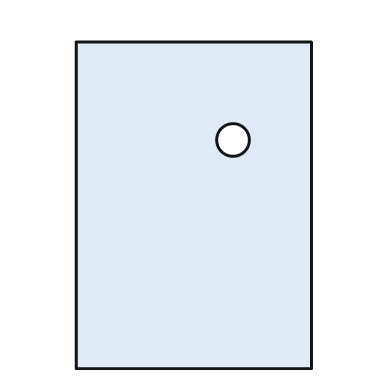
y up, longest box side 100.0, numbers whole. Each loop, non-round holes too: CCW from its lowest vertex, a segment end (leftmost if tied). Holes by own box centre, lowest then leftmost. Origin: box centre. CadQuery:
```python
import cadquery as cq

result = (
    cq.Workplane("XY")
    .moveTo(-36.0, -50.0)
    .lineTo(36.0, -50.0)
    .lineTo(36.0, 50.0)
    .lineTo(-36.0, 50.0)
    .close()
    .moveTo(12.0, 20.0)
    .circle(5.0)
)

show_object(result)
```